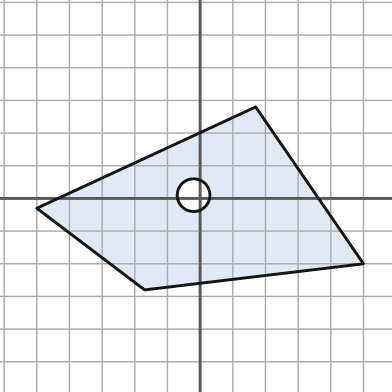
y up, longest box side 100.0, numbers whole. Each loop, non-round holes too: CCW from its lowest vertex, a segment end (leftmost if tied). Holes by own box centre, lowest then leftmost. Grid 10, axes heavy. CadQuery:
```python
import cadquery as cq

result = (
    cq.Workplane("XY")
    .moveTo(-17.0, -28.0)
    .lineTo(50.0, -20.0)
    .lineTo(17.0, 28.0)
    .lineTo(-50.0, -3.0)
    .close()
    .moveTo(-2.0, 1.0)
    .circle(5.0)
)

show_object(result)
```